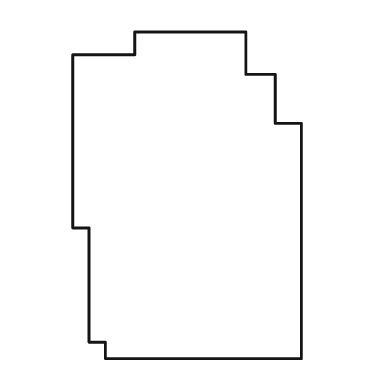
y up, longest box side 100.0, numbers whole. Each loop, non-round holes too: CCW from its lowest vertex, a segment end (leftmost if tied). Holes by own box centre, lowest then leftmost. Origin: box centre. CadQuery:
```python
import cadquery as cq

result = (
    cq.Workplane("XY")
    .moveTo(-25.0, -50.0)
    .lineTo(35.0, -50.0)
    .lineTo(35.0, 22.0)
    .lineTo(27.0, 22.0)
    .lineTo(27.0, 37.0)
    .lineTo(18.0, 37.0)
    .lineTo(18.0, 50.0)
    .lineTo(-16.0, 50.0)
    .lineTo(-16.0, 43.0)
    .lineTo(-35.0, 43.0)
    .lineTo(-35.0, -10.0)
    .lineTo(-30.0, -10.0)
    .lineTo(-30.0, -45.0)
    .lineTo(-25.0, -45.0)
    .close()
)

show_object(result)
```